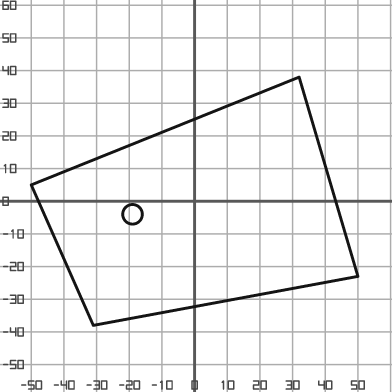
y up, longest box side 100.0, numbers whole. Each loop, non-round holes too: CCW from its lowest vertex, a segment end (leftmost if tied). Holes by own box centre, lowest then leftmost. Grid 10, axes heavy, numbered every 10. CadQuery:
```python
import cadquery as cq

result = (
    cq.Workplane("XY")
    .moveTo(-31.0, -38.0)
    .lineTo(50.0, -23.0)
    .lineTo(32.0, 38.0)
    .lineTo(-50.0, 5.0)
    .close()
    .moveTo(-19.0, -4.0)
    .circle(3.0)
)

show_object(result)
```